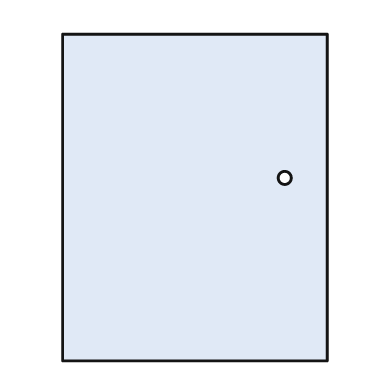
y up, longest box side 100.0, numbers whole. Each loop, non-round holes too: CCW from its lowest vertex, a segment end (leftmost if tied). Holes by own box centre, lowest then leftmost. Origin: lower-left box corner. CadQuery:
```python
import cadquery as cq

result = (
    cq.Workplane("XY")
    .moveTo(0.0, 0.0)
    .lineTo(81.0, 0.0)
    .lineTo(81.0, 100.0)
    .lineTo(0.0, 100.0)
    .close()
    .moveTo(68.0, 56.0)
    .circle(2.0)
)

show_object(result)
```